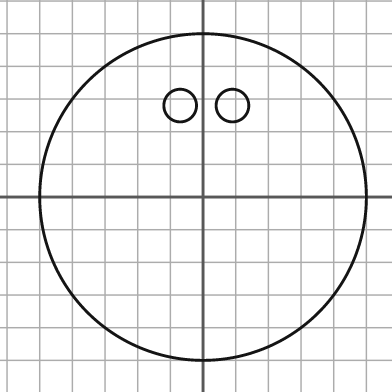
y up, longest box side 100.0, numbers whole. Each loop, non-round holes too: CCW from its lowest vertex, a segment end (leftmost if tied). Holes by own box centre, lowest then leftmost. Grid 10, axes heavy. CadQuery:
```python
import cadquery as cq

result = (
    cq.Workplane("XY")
    .moveTo(0.0, 0.0)
    .circle(50.0)
    .moveTo(-7.0, 28.0)
    .circle(5.0)
    .moveTo(9.0, 28.0)
    .circle(5.0)
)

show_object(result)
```